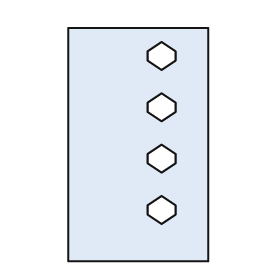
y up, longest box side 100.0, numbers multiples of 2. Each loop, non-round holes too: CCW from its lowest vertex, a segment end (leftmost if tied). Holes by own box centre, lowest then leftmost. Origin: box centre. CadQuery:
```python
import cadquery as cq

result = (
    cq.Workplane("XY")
    .moveTo(-30.0, -50.0)
    .lineTo(30.0, -50.0)
    .lineTo(30.0, 50.0)
    .lineTo(-30.0, 50.0)
    .close()
    .moveTo(10.0, -34.0)
    .lineTo(16.0, -30.0)
    .lineTo(16.0, -26.0)
    .lineTo(10.0, -22.0)
    .lineTo(4.0, -26.0)
    .lineTo(4.0, -30.0)
    .close()
    .moveTo(10.0, -12.0)
    .lineTo(16.0, -8.0)
    .lineTo(16.0, -4.0)
    .lineTo(10.0, 0.0)
    .lineTo(4.0, -4.0)
    .lineTo(4.0, -8.0)
    .close()
    .moveTo(10.0, 10.0)
    .lineTo(16.0, 14.0)
    .lineTo(16.0, 18.0)
    .lineTo(10.0, 22.0)
    .lineTo(4.0, 18.0)
    .lineTo(4.0, 14.0)
    .close()
    .moveTo(10.0, 32.0)
    .lineTo(16.0, 36.0)
    .lineTo(16.0, 40.0)
    .lineTo(10.0, 44.0)
    .lineTo(4.0, 40.0)
    .lineTo(4.0, 36.0)
    .close()
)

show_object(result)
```